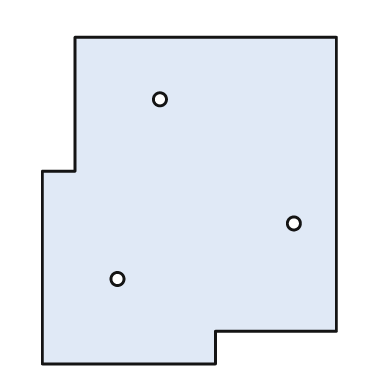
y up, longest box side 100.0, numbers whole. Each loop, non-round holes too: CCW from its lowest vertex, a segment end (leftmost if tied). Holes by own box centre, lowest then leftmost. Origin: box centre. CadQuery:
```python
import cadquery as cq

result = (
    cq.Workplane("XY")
    .moveTo(-45.0, -50.0)
    .lineTo(8.0, -50.0)
    .lineTo(8.0, -40.0)
    .lineTo(45.0, -40.0)
    .lineTo(45.0, 50.0)
    .lineTo(-35.0, 50.0)
    .lineTo(-35.0, 9.0)
    .lineTo(-45.0, 9.0)
    .close()
    .moveTo(-22.0, -24.0)
    .circle(2.0)
    .moveTo(32.0, -7.0)
    .circle(2.0)
    .moveTo(-9.0, 31.0)
    .circle(2.0)
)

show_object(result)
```